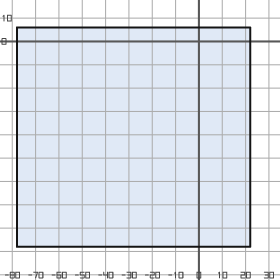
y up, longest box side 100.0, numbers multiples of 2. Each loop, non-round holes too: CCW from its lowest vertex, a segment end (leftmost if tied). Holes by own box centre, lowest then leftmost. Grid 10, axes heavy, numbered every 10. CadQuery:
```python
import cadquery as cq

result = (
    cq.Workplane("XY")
    .moveTo(-78.0, -88.0)
    .lineTo(22.0, -88.0)
    .lineTo(22.0, 6.0)
    .lineTo(-78.0, 6.0)
    .close()
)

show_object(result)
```